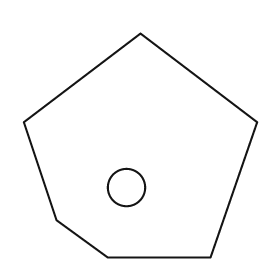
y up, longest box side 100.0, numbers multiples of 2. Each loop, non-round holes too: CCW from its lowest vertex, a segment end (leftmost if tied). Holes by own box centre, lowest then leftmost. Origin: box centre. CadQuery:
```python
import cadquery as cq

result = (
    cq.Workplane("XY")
    .moveTo(-14.0, -48.0)
    .lineTo(30.0, -48.0)
    .lineTo(50.0, 10.0)
    .lineTo(0.0, 48.0)
    .lineTo(-50.0, 10.0)
    .lineTo(-36.0, -32.0)
    .close()
    .moveTo(-6.0, -18.0)
    .circle(8.0)
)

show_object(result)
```